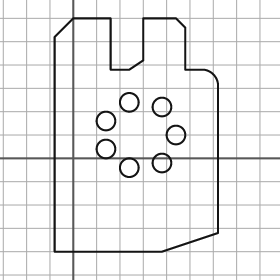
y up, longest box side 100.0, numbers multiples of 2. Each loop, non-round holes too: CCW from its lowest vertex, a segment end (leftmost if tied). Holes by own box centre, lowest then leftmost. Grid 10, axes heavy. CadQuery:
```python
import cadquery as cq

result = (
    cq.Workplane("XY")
    .moveTo(-8.0, -40.0)
    .lineTo(38.0, -40.0)
    .lineTo(62.0, -32.0)
    .lineTo(62.0, 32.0)
    .threePointArc((60.0, 36.0), (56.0, 38.0))
    .lineTo(48.0, 38.0)
    .lineTo(48.0, 56.0)
    .lineTo(44.0, 60.0)
    .lineTo(30.0, 60.0)
    .lineTo(30.0, 42.0)
    .lineTo(24.0, 38.0)
    .lineTo(16.0, 38.0)
    .lineTo(16.0, 60.0)
    .lineTo(0.0, 60.0)
    .lineTo(-8.0, 52.0)
    .close()
    .moveTo(24.0, -4.0)
    .circle(4.0)
    .moveTo(38.0, -2.0)
    .circle(4.0)
    .moveTo(14.0, 4.0)
    .circle(4.0)
    .moveTo(44.0, 10.0)
    .circle(4.0)
    .moveTo(14.0, 16.0)
    .circle(4.0)
    .moveTo(38.0, 22.0)
    .circle(4.0)
    .moveTo(24.0, 24.0)
    .circle(4.0)
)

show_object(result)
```